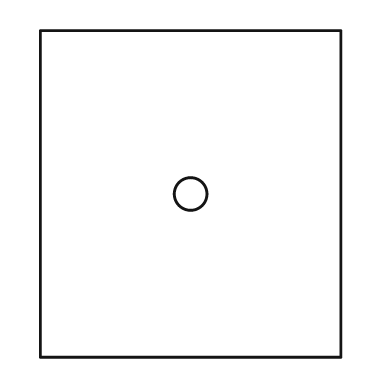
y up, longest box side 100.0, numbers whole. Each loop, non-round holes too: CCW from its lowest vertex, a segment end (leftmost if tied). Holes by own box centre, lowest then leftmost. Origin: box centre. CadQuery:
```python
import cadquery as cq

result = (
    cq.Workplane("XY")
    .moveTo(-46.0, -50.0)
    .lineTo(46.0, -50.0)
    .lineTo(46.0, 50.0)
    .lineTo(-46.0, 50.0)
    .close()
    .moveTo(0.0, 0.0)
    .circle(5.0)
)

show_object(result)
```